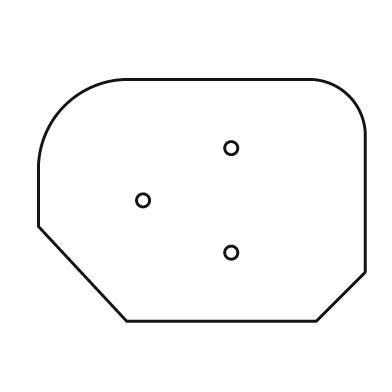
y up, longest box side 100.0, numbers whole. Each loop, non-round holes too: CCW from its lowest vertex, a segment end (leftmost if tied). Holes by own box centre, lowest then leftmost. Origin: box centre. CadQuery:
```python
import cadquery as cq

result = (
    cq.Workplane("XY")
    .moveTo(-23.0, -37.0)
    .lineTo(35.0, -37.0)
    .lineTo(50.0, -22.0)
    .lineTo(50.0, 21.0)
    .threePointArc((45.0, 32.0), (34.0, 37.0))
    .lineTo(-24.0, 37.0)
    .threePointArc((-42.0, 29.0), (-50.0, 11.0))
    .lineTo(-50.0, -8.0)
    .close()
    .moveTo(9.0, -16.0)
    .circle(2.0)
    .moveTo(-18.0, 0.0)
    .circle(2.0)
    .moveTo(9.0, 16.0)
    .circle(2.0)
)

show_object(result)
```